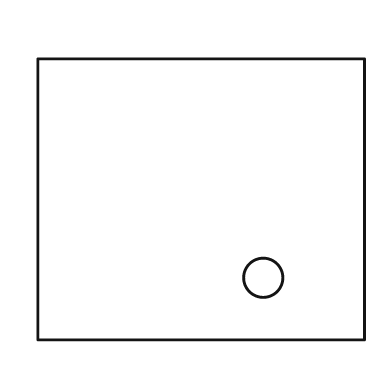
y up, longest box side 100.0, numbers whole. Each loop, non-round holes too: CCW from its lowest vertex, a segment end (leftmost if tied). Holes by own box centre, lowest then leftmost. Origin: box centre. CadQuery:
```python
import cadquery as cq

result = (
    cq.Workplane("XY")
    .moveTo(-50.0, -43.0)
    .lineTo(50.0, -43.0)
    .lineTo(50.0, 43.0)
    .lineTo(-50.0, 43.0)
    .close()
    .moveTo(19.0, -24.0)
    .circle(6.0)
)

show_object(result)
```